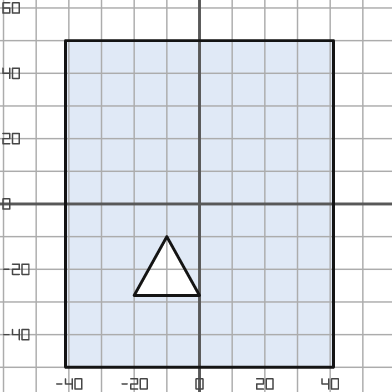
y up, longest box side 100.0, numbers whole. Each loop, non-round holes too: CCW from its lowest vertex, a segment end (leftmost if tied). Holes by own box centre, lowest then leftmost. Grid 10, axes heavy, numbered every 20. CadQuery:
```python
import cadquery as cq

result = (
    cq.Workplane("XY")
    .moveTo(-41.0, -50.0)
    .lineTo(41.0, -50.0)
    .lineTo(41.0, 50.0)
    .lineTo(-41.0, 50.0)
    .close()
    .moveTo(-20.0, -28.0)
    .lineTo(0.0, -28.0)
    .lineTo(-10.0, -10.0)
    .close()
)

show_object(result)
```